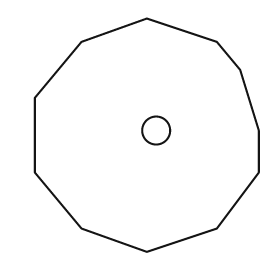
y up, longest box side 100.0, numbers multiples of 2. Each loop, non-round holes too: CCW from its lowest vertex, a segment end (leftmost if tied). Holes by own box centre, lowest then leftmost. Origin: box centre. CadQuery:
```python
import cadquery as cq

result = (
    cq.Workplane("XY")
    .moveTo(0.0, -50.0)
    .lineTo(30.0, -40.0)
    .lineTo(48.0, -16.0)
    .lineTo(48.0, 2.0)
    .lineTo(40.0, 28.0)
    .lineTo(30.0, 40.0)
    .lineTo(0.0, 50.0)
    .lineTo(-28.0, 40.0)
    .lineTo(-48.0, 16.0)
    .lineTo(-48.0, -16.0)
    .lineTo(-28.0, -40.0)
    .close()
    .moveTo(4.0, 2.0)
    .circle(6.0)
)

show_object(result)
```